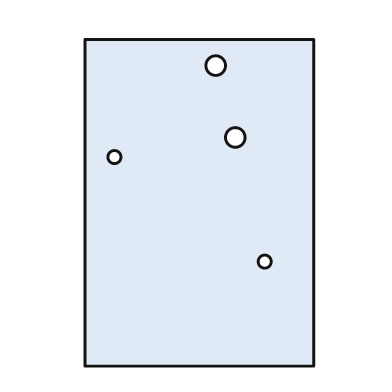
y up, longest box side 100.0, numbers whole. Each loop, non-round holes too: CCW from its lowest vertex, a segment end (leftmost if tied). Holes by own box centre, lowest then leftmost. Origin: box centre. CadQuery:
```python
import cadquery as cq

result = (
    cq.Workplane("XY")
    .moveTo(-35.0, -50.0)
    .lineTo(35.0, -50.0)
    .lineTo(35.0, 50.0)
    .lineTo(-35.0, 50.0)
    .close()
    .moveTo(20.0, -18.0)
    .circle(2.0)
    .moveTo(-26.0, 14.0)
    .circle(2.0)
    .moveTo(11.0, 20.0)
    .circle(3.0)
    .moveTo(5.0, 42.0)
    .circle(3.0)
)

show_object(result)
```